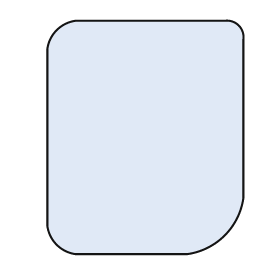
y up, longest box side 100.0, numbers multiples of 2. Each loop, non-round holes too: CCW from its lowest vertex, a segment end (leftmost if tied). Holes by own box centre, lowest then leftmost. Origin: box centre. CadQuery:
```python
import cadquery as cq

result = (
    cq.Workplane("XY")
    .moveTo(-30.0, -50.0)
    .lineTo(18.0, -50.0)
    .threePointArc((34.0, -42.0), (42.0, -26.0))
    .lineTo(42.0, 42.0)
    .threePointArc((40.0, 48.0), (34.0, 50.0))
    .lineTo(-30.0, 50.0)
    .threePointArc((-38.0, 46.0), (-42.0, 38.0))
    .lineTo(-42.0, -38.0)
    .threePointArc((-38.0, -46.0), (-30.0, -50.0))
    .close()
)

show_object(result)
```